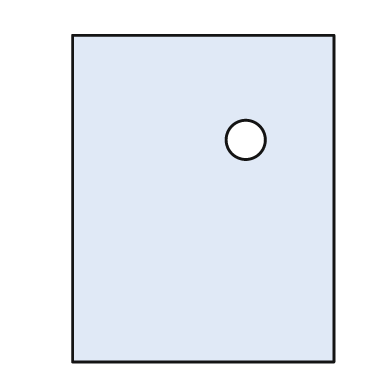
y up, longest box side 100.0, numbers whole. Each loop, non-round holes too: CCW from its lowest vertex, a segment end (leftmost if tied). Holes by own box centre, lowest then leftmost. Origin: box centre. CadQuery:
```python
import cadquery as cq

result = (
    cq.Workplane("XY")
    .moveTo(-40.0, -50.0)
    .lineTo(40.0, -50.0)
    .lineTo(40.0, 50.0)
    .lineTo(-40.0, 50.0)
    .close()
    .moveTo(13.0, 18.0)
    .circle(6.0)
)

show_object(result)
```